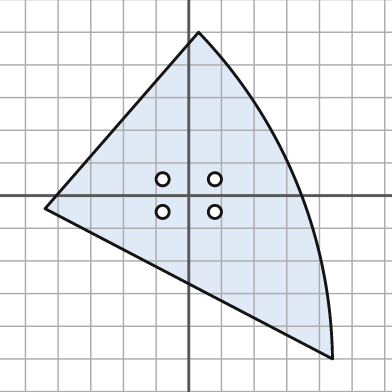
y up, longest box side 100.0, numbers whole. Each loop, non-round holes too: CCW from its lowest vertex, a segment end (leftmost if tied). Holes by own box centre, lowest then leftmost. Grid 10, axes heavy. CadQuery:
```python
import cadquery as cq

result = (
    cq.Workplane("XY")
    .moveTo(44.0, -50.0)
    .threePointArc((33.0, 4.0), (3.0, 50.0))
    .lineTo(-44.0, -4.0)
    .close()
    .moveTo(-8.0, -5.0)
    .circle(2.0)
    .moveTo(8.0, -5.0)
    .circle(2.0)
    .moveTo(-8.0, 5.0)
    .circle(2.0)
    .moveTo(8.0, 5.0)
    .circle(2.0)
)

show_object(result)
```